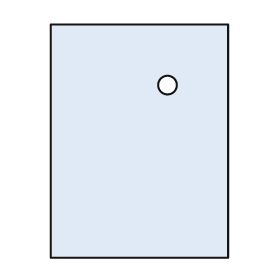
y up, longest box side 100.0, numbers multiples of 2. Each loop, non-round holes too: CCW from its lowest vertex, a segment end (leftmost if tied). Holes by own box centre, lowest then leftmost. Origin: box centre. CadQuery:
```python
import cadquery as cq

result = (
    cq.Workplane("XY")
    .moveTo(-38.0, -50.0)
    .lineTo(38.0, -50.0)
    .lineTo(38.0, 50.0)
    .lineTo(-38.0, 50.0)
    .close()
    .moveTo(12.0, 24.0)
    .circle(4.0)
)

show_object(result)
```